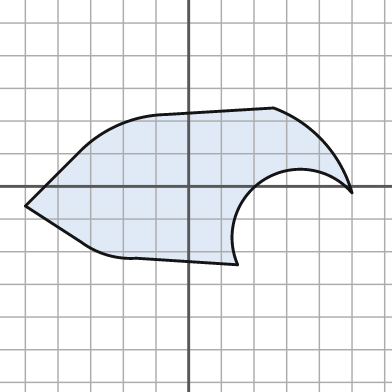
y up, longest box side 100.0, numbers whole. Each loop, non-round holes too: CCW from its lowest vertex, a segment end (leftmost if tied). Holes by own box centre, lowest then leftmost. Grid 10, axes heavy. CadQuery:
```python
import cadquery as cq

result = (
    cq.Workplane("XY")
    .moveTo(15.0, -24.0)
    .threePointArc((23.0, 2.0), (50.0, -2.0))
    .threePointArc((41.0, 14.0), (26.0, 24.0))
    .lineTo(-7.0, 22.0)
    .threePointArc((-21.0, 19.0), (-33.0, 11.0))
    .lineTo(-50.0, -6.0)
    .lineTo(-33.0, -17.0)
    .threePointArc((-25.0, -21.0), (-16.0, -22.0))
    .close()
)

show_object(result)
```